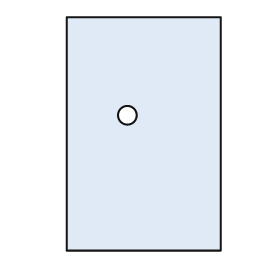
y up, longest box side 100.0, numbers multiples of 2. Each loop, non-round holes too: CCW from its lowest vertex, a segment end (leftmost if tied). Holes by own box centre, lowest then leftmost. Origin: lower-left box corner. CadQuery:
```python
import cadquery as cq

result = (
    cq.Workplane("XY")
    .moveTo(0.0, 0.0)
    .lineTo(66.0, 0.0)
    .lineTo(66.0, 100.0)
    .lineTo(0.0, 100.0)
    .close()
    .moveTo(26.0, 58.0)
    .circle(4.0)
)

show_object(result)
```